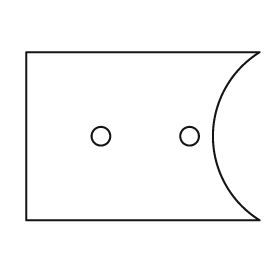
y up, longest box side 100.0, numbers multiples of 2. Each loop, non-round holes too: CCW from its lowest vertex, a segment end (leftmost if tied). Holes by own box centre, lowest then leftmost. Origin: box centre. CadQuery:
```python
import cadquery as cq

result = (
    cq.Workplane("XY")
    .moveTo(-50.0, -36.0)
    .lineTo(50.0, -36.0)
    .threePointArc((30.0, 0.0), (50.0, 36.0))
    .lineTo(-50.0, 36.0)
    .close()
    .moveTo(-18.0, 0.0)
    .circle(4.0)
    .moveTo(20.0, 0.0)
    .circle(4.0)
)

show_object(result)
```